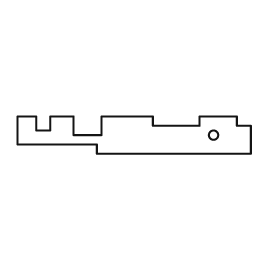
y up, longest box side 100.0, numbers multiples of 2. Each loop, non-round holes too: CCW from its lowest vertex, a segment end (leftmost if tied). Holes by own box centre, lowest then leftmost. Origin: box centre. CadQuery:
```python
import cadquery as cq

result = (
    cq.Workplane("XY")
    .moveTo(-16.0, -8.0)
    .lineTo(50.0, -8.0)
    .lineTo(50.0, 4.0)
    .lineTo(44.0, 4.0)
    .lineTo(44.0, 8.0)
    .lineTo(28.0, 8.0)
    .lineTo(28.0, 4.0)
    .lineTo(8.0, 4.0)
    .lineTo(8.0, 8.0)
    .lineTo(-14.0, 8.0)
    .lineTo(-14.0, 0.0)
    .lineTo(-26.0, 0.0)
    .lineTo(-26.0, 8.0)
    .lineTo(-36.0, 8.0)
    .lineTo(-36.0, 2.0)
    .lineTo(-42.0, 2.0)
    .lineTo(-42.0, 8.0)
    .lineTo(-50.0, 8.0)
    .lineTo(-50.0, -4.0)
    .lineTo(-16.0, -4.0)
    .close()
    .moveTo(34.0, 0.0)
    .circle(2.0)
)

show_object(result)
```